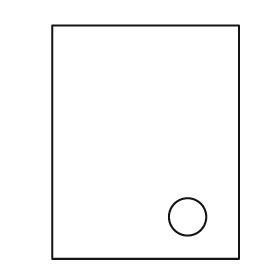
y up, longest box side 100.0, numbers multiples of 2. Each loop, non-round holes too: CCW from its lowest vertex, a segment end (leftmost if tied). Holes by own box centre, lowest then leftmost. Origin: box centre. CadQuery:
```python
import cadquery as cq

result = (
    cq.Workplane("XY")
    .moveTo(-40.0, -50.0)
    .lineTo(40.0, -50.0)
    .lineTo(40.0, 50.0)
    .lineTo(-40.0, 50.0)
    .close()
    .moveTo(18.0, -32.0)
    .circle(8.0)
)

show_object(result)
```